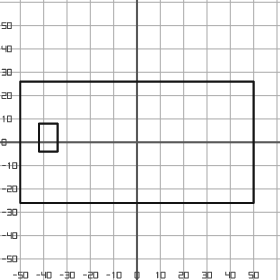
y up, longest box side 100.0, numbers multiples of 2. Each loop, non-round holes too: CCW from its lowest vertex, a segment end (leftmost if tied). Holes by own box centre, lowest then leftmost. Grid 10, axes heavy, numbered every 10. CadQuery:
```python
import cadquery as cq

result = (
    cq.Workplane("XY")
    .moveTo(-50.0, -26.0)
    .lineTo(50.0, -26.0)
    .lineTo(50.0, 26.0)
    .lineTo(-50.0, 26.0)
    .close()
    .moveTo(-42.0, -4.0)
    .lineTo(-34.0, -4.0)
    .lineTo(-34.0, 8.0)
    .lineTo(-42.0, 8.0)
    .close()
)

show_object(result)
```